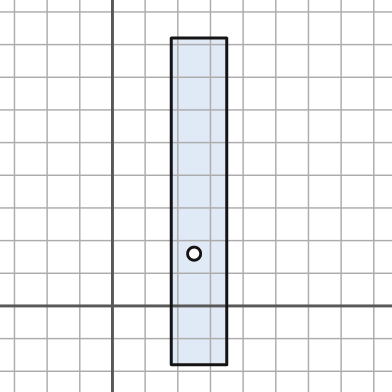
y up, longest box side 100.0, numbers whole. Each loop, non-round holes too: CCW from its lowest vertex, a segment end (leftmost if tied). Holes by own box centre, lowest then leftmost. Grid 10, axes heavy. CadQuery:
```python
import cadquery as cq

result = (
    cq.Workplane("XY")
    .moveTo(18.0, -18.0)
    .lineTo(35.0, -18.0)
    .lineTo(35.0, 82.0)
    .lineTo(18.0, 82.0)
    .close()
    .moveTo(25.0, 16.0)
    .circle(2.0)
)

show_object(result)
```